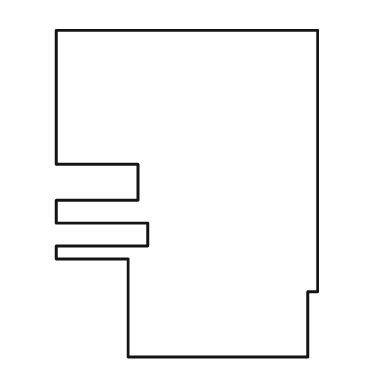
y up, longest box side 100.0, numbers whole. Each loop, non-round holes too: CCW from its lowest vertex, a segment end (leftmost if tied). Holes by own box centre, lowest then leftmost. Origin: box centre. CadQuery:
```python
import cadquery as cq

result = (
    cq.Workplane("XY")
    .moveTo(-18.0, -50.0)
    .lineTo(37.0, -50.0)
    .lineTo(37.0, -30.0)
    .lineTo(40.0, -30.0)
    .lineTo(40.0, 50.0)
    .lineTo(-40.0, 50.0)
    .lineTo(-40.0, 9.0)
    .lineTo(-15.0, 9.0)
    .lineTo(-15.0, -2.0)
    .lineTo(-40.0, -2.0)
    .lineTo(-40.0, -9.0)
    .lineTo(-12.0, -9.0)
    .lineTo(-12.0, -16.0)
    .lineTo(-40.0, -16.0)
    .lineTo(-40.0, -20.0)
    .lineTo(-18.0, -20.0)
    .close()
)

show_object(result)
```